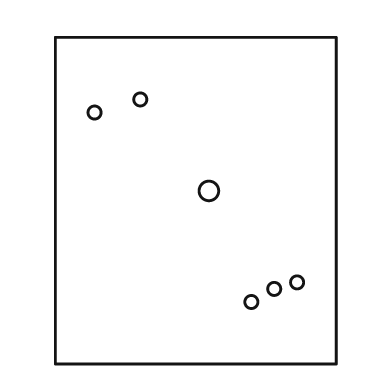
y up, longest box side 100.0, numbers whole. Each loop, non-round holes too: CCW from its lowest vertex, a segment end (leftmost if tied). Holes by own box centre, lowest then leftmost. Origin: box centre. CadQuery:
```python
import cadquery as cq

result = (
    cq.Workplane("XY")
    .moveTo(-43.0, -50.0)
    .lineTo(43.0, -50.0)
    .lineTo(43.0, 50.0)
    .lineTo(-43.0, 50.0)
    .close()
    .moveTo(17.0, -31.0)
    .circle(2.0)
    .moveTo(24.0, -27.0)
    .circle(2.0)
    .moveTo(31.0, -25.0)
    .circle(2.0)
    .moveTo(4.0, 3.0)
    .circle(3.0)
    .moveTo(-31.0, 27.0)
    .circle(2.0)
    .moveTo(-17.0, 31.0)
    .circle(2.0)
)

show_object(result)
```